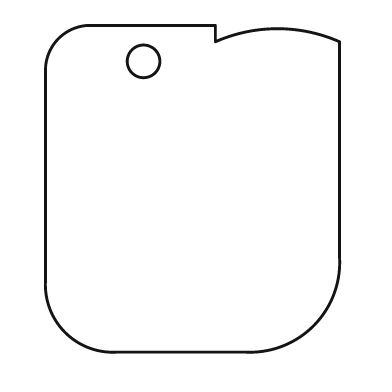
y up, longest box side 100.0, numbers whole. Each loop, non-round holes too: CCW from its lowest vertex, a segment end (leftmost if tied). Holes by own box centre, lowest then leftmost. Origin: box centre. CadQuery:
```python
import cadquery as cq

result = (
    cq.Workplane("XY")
    .moveTo(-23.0, -50.0)
    .lineTo(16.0, -50.0)
    .threePointArc((37.0, -42.0), (45.0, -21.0))
    .lineTo(45.0, 45.0)
    .threePointArc((26.0, 49.0), (7.0, 45.0))
    .lineTo(7.0, 50.0)
    .lineTo(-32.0, 50.0)
    .threePointArc((-41.0, 46.0), (-45.0, 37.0))
    .lineTo(-45.0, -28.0)
    .threePointArc((-39.0, -44.0), (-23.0, -50.0))
    .close()
    .moveTo(-15.0, 39.0)
    .circle(5.0)
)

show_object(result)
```